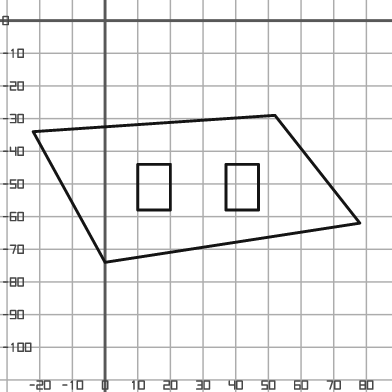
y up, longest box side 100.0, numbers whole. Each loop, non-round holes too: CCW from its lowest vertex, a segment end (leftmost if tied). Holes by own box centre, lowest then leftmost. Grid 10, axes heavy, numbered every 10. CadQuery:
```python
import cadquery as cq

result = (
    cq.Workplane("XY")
    .moveTo(0.0, -74.0)
    .lineTo(78.0, -62.0)
    .lineTo(52.0, -29.0)
    .lineTo(-22.0, -34.0)
    .close()
    .moveTo(10.0, -58.0)
    .lineTo(20.0, -58.0)
    .lineTo(20.0, -44.0)
    .lineTo(10.0, -44.0)
    .close()
    .moveTo(37.0, -58.0)
    .lineTo(47.0, -58.0)
    .lineTo(47.0, -44.0)
    .lineTo(37.0, -44.0)
    .close()
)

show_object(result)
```